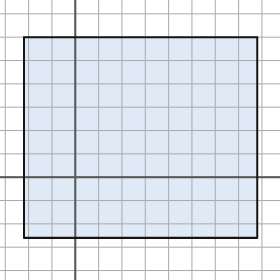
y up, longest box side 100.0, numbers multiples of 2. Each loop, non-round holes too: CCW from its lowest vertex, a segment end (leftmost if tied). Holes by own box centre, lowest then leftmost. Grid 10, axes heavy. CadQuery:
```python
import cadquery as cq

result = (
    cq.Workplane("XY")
    .moveTo(-22.0, -26.0)
    .lineTo(78.0, -26.0)
    .lineTo(78.0, 60.0)
    .lineTo(-22.0, 60.0)
    .close()
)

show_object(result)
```